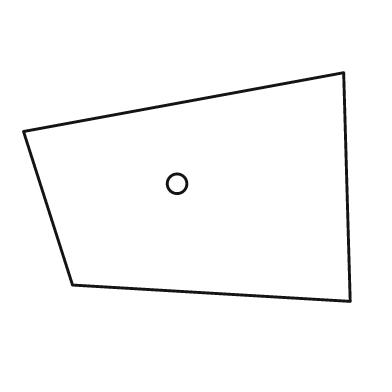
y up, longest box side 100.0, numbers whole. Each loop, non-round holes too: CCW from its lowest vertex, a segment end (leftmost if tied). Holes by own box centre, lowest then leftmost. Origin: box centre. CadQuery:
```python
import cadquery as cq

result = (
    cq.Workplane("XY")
    .moveTo(50.0, -35.0)
    .lineTo(48.0, 35.0)
    .lineTo(-50.0, 17.0)
    .lineTo(-35.0, -30.0)
    .close()
    .moveTo(-3.0, 1.0)
    .circle(3.0)
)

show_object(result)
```